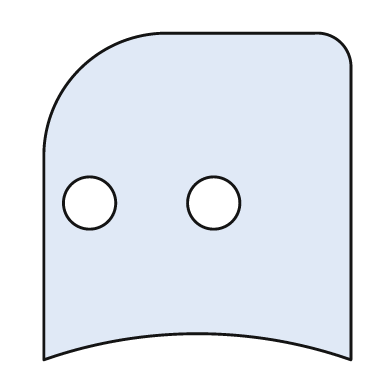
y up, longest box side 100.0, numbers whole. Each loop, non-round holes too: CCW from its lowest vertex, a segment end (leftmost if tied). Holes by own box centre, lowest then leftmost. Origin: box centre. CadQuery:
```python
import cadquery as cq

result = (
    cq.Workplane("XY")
    .moveTo(-47.0, -50.0)
    .threePointArc((0.0, -42.0), (47.0, -50.0))
    .lineTo(47.0, 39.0)
    .threePointArc((44.0, 47.0), (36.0, 50.0))
    .lineTo(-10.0, 50.0)
    .threePointArc((-36.0, 39.0), (-47.0, 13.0))
    .close()
    .moveTo(-33.0, -2.0)
    .circle(8.0)
    .moveTo(5.0, -2.0)
    .circle(8.0)
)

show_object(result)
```